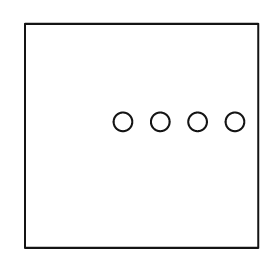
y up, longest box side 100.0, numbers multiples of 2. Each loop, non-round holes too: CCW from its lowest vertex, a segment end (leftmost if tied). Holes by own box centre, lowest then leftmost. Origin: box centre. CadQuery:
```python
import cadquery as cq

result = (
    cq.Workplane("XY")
    .moveTo(-50.0, -48.0)
    .lineTo(50.0, -48.0)
    .lineTo(50.0, 48.0)
    .lineTo(-50.0, 48.0)
    .close()
    .moveTo(-8.0, 6.0)
    .circle(4.0)
    .moveTo(8.0, 6.0)
    .circle(4.0)
    .moveTo(24.0, 6.0)
    .circle(4.0)
    .moveTo(40.0, 6.0)
    .circle(4.0)
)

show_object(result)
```